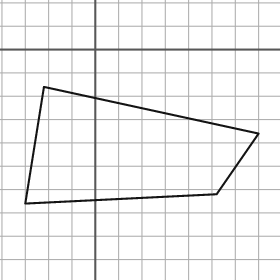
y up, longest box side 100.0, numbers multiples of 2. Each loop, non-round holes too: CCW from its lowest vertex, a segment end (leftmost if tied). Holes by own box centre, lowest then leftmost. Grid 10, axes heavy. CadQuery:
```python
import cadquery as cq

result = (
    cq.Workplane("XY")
    .moveTo(-30.0, -66.0)
    .lineTo(52.0, -62.0)
    .lineTo(70.0, -36.0)
    .lineTo(-22.0, -16.0)
    .close()
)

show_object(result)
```